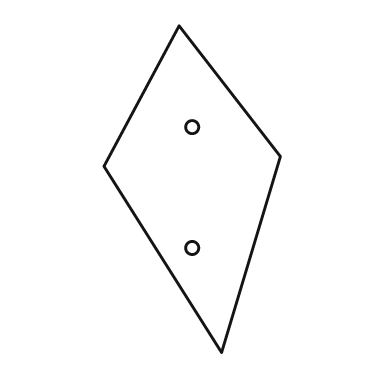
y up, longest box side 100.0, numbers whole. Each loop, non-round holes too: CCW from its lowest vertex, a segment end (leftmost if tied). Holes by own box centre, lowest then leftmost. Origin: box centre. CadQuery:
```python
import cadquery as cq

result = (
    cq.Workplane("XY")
    .moveTo(9.0, -50.0)
    .lineTo(27.0, 10.0)
    .lineTo(-4.0, 50.0)
    .lineTo(-27.0, 7.0)
    .close()
    .moveTo(0.0, -18.0)
    .circle(2.0)
    .moveTo(0.0, 19.0)
    .circle(2.0)
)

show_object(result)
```